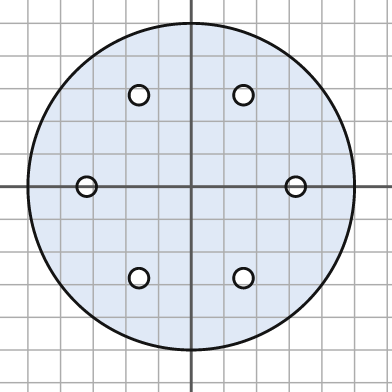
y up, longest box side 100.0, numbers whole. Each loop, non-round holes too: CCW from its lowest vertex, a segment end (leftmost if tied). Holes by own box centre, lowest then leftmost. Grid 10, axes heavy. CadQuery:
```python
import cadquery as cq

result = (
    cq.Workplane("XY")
    .moveTo(0.0, 0.0)
    .circle(50.0)
    .moveTo(-16.0, -28.0)
    .circle(3.0)
    .moveTo(16.0, -28.0)
    .circle(3.0)
    .moveTo(-32.0, 0.0)
    .circle(3.0)
    .moveTo(32.0, 0.0)
    .circle(3.0)
    .moveTo(-16.0, 28.0)
    .circle(3.0)
    .moveTo(16.0, 28.0)
    .circle(3.0)
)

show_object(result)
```